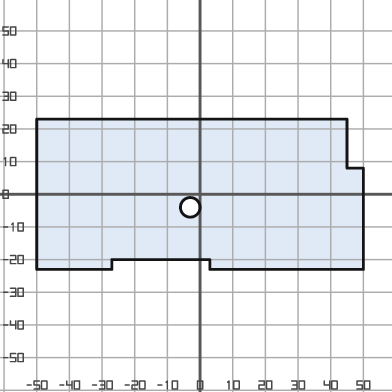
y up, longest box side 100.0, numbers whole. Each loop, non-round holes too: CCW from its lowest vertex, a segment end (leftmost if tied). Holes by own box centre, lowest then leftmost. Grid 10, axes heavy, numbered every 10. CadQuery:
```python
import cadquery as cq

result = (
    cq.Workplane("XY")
    .moveTo(-50.0, -23.0)
    .lineTo(-27.0, -23.0)
    .lineTo(-27.0, -20.0)
    .lineTo(3.0, -20.0)
    .lineTo(3.0, -23.0)
    .lineTo(50.0, -23.0)
    .lineTo(50.0, 8.0)
    .lineTo(45.0, 8.0)
    .lineTo(45.0, 23.0)
    .lineTo(-50.0, 23.0)
    .close()
    .moveTo(-3.0, -4.0)
    .circle(3.0)
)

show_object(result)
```